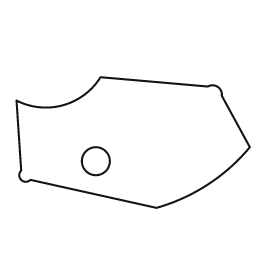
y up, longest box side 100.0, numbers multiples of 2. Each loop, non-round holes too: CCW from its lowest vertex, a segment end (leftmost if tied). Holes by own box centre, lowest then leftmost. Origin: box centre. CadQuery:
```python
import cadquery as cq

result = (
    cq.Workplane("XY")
    .moveTo(10.0, -28.0)
    .threePointArc((32.0, -18.0), (50.0, -2.0))
    .lineTo(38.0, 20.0)
    .threePointArc((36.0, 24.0), (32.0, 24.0))
    .lineTo(-14.0, 28.0)
    .threePointArc((-30.0, 16.0), (-50.0, 18.0))
    .lineTo(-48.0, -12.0)
    .threePointArc((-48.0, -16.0), (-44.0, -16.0))
    .close()
    .moveTo(-16.0, -8.0)
    .circle(6.0)
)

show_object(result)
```